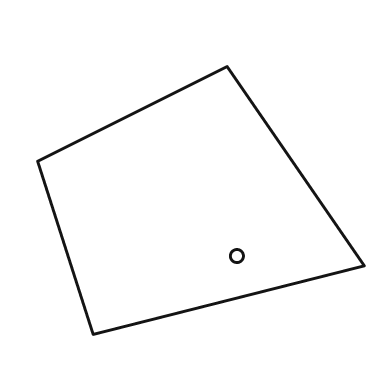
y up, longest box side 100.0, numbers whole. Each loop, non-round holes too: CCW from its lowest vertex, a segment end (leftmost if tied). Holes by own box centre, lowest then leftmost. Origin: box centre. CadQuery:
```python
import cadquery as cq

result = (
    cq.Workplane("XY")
    .moveTo(-33.0, -41.0)
    .lineTo(50.0, -20.0)
    .lineTo(8.0, 41.0)
    .lineTo(-50.0, 12.0)
    .close()
    .moveTo(11.0, -17.0)
    .circle(2.0)
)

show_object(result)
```